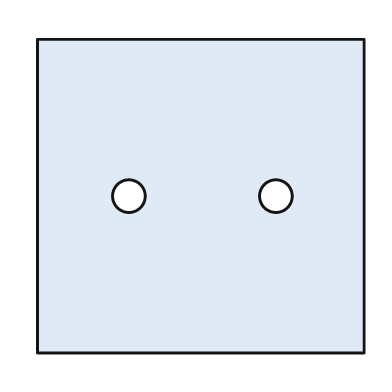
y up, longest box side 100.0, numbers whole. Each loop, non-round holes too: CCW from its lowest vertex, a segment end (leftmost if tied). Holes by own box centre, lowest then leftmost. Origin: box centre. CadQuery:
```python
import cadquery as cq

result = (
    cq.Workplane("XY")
    .moveTo(-50.0, -48.0)
    .lineTo(50.0, -48.0)
    .lineTo(50.0, 48.0)
    .lineTo(-50.0, 48.0)
    .close()
    .moveTo(-22.0, 0.0)
    .circle(5.0)
    .moveTo(23.0, 0.0)
    .circle(5.0)
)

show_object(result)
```